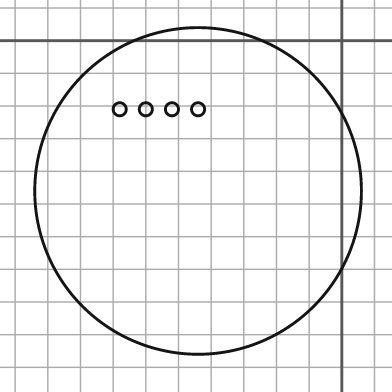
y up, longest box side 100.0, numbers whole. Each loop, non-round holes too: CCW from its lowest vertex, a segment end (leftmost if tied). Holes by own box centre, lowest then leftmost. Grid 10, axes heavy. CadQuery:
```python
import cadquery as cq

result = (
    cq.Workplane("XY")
    .moveTo(-44.0, -46.0)
    .circle(50.0)
    .moveTo(-68.0, -21.0)
    .circle(2.0)
    .moveTo(-60.0, -21.0)
    .circle(2.0)
    .moveTo(-52.0, -21.0)
    .circle(2.0)
    .moveTo(-44.0, -21.0)
    .circle(2.0)
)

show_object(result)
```